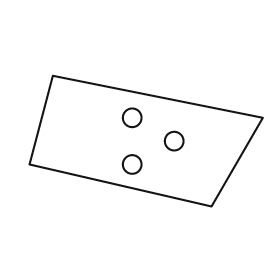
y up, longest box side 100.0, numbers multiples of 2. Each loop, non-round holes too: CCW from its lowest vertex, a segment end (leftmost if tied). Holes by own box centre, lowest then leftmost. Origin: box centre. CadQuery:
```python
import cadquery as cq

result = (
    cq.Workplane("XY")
    .moveTo(28.0, -28.0)
    .lineTo(50.0, 10.0)
    .lineTo(-40.0, 28.0)
    .lineTo(-50.0, -10.0)
    .close()
    .moveTo(-6.0, -10.0)
    .circle(4.0)
    .moveTo(12.0, 0.0)
    .circle(4.0)
    .moveTo(-6.0, 10.0)
    .circle(4.0)
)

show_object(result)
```